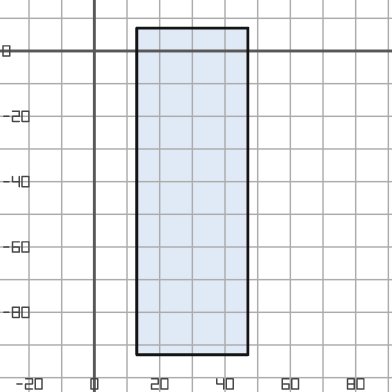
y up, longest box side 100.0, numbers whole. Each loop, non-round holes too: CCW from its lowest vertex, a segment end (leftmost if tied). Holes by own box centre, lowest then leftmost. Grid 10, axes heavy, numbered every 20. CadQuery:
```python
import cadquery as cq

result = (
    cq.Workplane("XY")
    .moveTo(13.0, -93.0)
    .lineTo(47.0, -93.0)
    .lineTo(47.0, 7.0)
    .lineTo(13.0, 7.0)
    .close()
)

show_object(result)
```